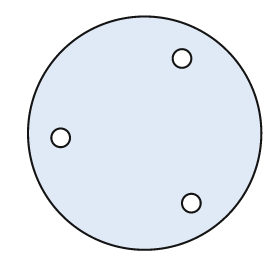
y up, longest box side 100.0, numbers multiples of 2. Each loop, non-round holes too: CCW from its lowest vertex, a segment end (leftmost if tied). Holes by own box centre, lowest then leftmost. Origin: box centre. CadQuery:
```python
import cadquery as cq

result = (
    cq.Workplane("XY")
    .moveTo(0.0, 0.0)
    .circle(50.0)
    .moveTo(20.0, -30.0)
    .circle(4.0)
    .moveTo(-36.0, -2.0)
    .circle(4.0)
    .moveTo(16.0, 32.0)
    .circle(4.0)
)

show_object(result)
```